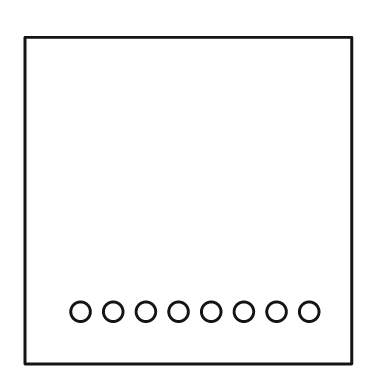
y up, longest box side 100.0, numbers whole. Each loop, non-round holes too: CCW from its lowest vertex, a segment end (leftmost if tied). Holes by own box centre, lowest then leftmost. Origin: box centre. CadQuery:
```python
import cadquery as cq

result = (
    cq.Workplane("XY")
    .moveTo(-50.0, -50.0)
    .lineTo(50.0, -50.0)
    .lineTo(50.0, 50.0)
    .lineTo(-50.0, 50.0)
    .close()
    .moveTo(-33.0, -34.0)
    .circle(3.0)
    .moveTo(-23.0, -34.0)
    .circle(3.0)
    .moveTo(-13.0, -34.0)
    .circle(3.0)
    .moveTo(-3.0, -34.0)
    .circle(3.0)
    .moveTo(7.0, -34.0)
    .circle(3.0)
    .moveTo(17.0, -34.0)
    .circle(3.0)
    .moveTo(27.0, -34.0)
    .circle(3.0)
    .moveTo(37.0, -34.0)
    .circle(3.0)
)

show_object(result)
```